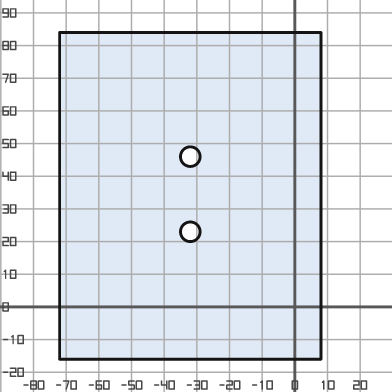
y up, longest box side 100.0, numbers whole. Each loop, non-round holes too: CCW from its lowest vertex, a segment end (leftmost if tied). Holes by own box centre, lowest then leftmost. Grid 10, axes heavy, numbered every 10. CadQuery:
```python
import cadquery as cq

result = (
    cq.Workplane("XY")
    .moveTo(-72.0, -16.0)
    .lineTo(8.0, -16.0)
    .lineTo(8.0, 84.0)
    .lineTo(-72.0, 84.0)
    .close()
    .moveTo(-32.0, 23.0)
    .circle(3.0)
    .moveTo(-32.0, 46.0)
    .circle(3.0)
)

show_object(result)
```